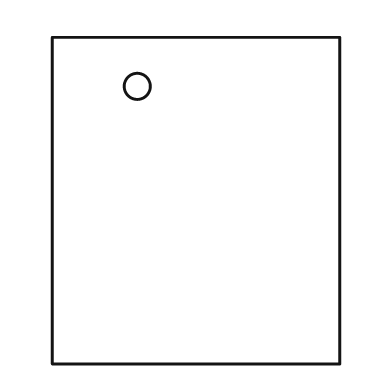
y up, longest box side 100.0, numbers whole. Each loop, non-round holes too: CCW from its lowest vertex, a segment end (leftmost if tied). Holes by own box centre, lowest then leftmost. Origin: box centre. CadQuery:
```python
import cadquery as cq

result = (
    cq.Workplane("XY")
    .moveTo(-44.0, -50.0)
    .lineTo(44.0, -50.0)
    .lineTo(44.0, 50.0)
    .lineTo(-44.0, 50.0)
    .close()
    .moveTo(-18.0, 35.0)
    .circle(4.0)
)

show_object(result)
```